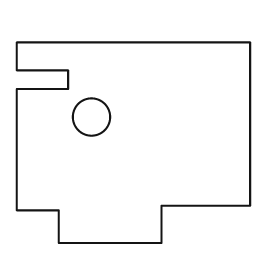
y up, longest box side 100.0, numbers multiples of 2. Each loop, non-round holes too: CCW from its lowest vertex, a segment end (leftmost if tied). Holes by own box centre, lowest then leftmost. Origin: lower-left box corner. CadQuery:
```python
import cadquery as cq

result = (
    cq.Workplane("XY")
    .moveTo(18.0, 0.0)
    .lineTo(62.0, 0.0)
    .lineTo(62.0, 16.0)
    .lineTo(100.0, 16.0)
    .lineTo(100.0, 86.0)
    .lineTo(0.0, 86.0)
    .lineTo(0.0, 74.0)
    .lineTo(22.0, 74.0)
    .lineTo(22.0, 66.0)
    .lineTo(0.0, 66.0)
    .lineTo(0.0, 14.0)
    .lineTo(18.0, 14.0)
    .close()
    .moveTo(32.0, 54.0)
    .circle(8.0)
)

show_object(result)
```